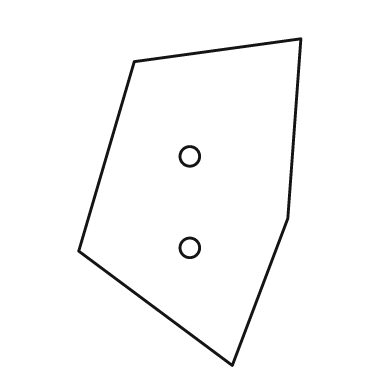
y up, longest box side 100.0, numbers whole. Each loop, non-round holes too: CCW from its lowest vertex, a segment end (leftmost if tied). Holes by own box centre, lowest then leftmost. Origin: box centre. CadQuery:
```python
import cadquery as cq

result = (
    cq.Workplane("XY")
    .moveTo(13.0, -50.0)
    .lineTo(30.0, -5.0)
    .lineTo(34.0, 50.0)
    .lineTo(-17.0, 43.0)
    .lineTo(-34.0, -15.0)
    .close()
    .moveTo(0.0, -14.0)
    .circle(3.0)
    .moveTo(0.0, 14.0)
    .circle(3.0)
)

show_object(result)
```